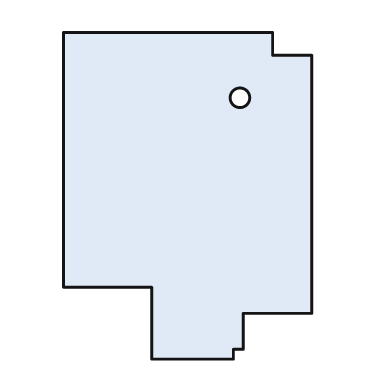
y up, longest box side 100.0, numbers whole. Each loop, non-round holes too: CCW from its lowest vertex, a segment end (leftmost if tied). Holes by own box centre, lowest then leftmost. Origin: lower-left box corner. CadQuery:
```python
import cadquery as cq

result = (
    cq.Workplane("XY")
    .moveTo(27.0, 0.0)
    .lineTo(52.0, 0.0)
    .lineTo(52.0, 3.0)
    .lineTo(55.0, 3.0)
    .lineTo(55.0, 14.0)
    .lineTo(76.0, 14.0)
    .lineTo(76.0, 93.0)
    .lineTo(64.0, 93.0)
    .lineTo(64.0, 100.0)
    .lineTo(0.0, 100.0)
    .lineTo(0.0, 22.0)
    .lineTo(27.0, 22.0)
    .close()
    .moveTo(54.0, 80.0)
    .circle(3.0)
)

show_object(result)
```